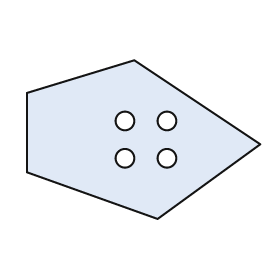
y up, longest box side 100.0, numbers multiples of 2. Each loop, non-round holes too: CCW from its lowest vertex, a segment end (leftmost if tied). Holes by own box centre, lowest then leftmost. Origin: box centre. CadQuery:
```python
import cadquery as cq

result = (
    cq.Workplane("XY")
    .moveTo(6.0, -34.0)
    .lineTo(50.0, -2.0)
    .lineTo(-4.0, 34.0)
    .lineTo(-50.0, 20.0)
    .lineTo(-50.0, -14.0)
    .close()
    .moveTo(-8.0, -8.0)
    .circle(4.0)
    .moveTo(10.0, -8.0)
    .circle(4.0)
    .moveTo(-8.0, 8.0)
    .circle(4.0)
    .moveTo(10.0, 8.0)
    .circle(4.0)
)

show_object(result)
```